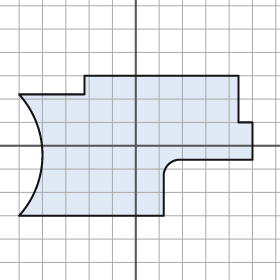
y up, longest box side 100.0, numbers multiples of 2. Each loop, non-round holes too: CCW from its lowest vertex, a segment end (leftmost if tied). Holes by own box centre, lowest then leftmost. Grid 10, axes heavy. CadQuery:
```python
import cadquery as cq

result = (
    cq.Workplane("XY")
    .moveTo(-50.0, -30.0)
    .lineTo(12.0, -30.0)
    .lineTo(12.0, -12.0)
    .threePointArc((14.0, -8.0), (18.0, -6.0))
    .lineTo(50.0, -6.0)
    .lineTo(50.0, 10.0)
    .lineTo(44.0, 10.0)
    .lineTo(44.0, 30.0)
    .lineTo(-22.0, 30.0)
    .lineTo(-22.0, 22.0)
    .lineTo(-50.0, 22.0)
    .threePointArc((-40.0, -4.0), (-50.0, -30.0))
    .close()
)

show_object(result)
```